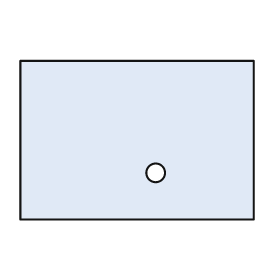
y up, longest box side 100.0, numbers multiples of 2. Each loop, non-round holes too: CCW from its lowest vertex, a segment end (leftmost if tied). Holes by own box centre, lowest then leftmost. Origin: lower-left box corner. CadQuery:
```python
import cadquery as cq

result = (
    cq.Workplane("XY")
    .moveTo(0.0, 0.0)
    .lineTo(100.0, 0.0)
    .lineTo(100.0, 68.0)
    .lineTo(0.0, 68.0)
    .close()
    .moveTo(58.0, 20.0)
    .circle(4.0)
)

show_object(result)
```